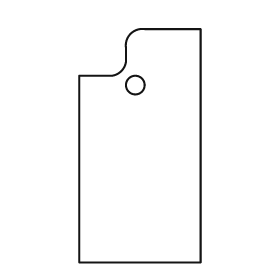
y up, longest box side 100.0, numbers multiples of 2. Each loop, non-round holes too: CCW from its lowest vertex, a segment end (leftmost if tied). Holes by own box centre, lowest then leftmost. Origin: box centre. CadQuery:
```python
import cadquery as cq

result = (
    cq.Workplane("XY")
    .moveTo(-26.0, -50.0)
    .lineTo(26.0, -50.0)
    .lineTo(26.0, 50.0)
    .lineTo(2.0, 50.0)
    .threePointArc((-4.0, 48.0), (-6.0, 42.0))
    .lineTo(-6.0, 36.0)
    .threePointArc((-8.0, 32.0), (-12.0, 30.0))
    .lineTo(-26.0, 30.0)
    .close()
    .moveTo(-2.0, 26.0)
    .circle(4.0)
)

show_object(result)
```